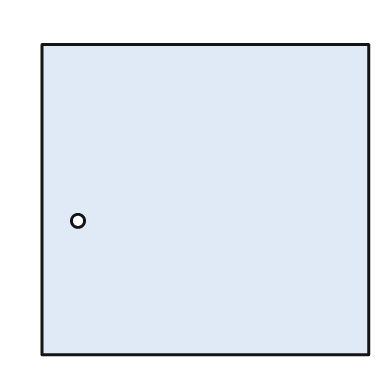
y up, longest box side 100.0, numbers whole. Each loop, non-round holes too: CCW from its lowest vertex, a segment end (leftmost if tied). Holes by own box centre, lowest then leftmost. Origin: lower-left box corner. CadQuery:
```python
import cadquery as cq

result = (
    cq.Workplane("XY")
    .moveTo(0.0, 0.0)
    .lineTo(100.0, 0.0)
    .lineTo(100.0, 95.0)
    .lineTo(0.0, 95.0)
    .close()
    .moveTo(11.0, 41.0)
    .circle(2.0)
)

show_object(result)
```